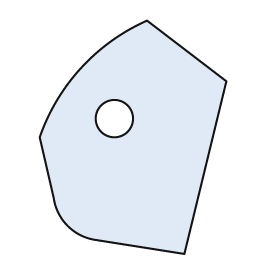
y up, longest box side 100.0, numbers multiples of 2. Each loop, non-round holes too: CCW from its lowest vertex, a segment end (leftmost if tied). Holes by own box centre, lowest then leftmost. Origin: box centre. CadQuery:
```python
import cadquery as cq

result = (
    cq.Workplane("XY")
    .moveTo(22.0, -50.0)
    .lineTo(40.0, 24.0)
    .lineTo(6.0, 50.0)
    .threePointArc((-22.0, 30.0), (-40.0, 0.0))
    .lineTo(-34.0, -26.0)
    .threePointArc((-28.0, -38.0), (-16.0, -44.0))
    .close()
    .moveTo(-8.0, 8.0)
    .circle(8.0)
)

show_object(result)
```